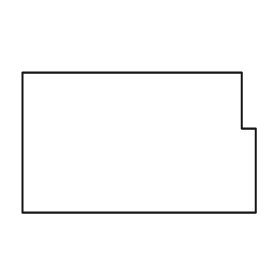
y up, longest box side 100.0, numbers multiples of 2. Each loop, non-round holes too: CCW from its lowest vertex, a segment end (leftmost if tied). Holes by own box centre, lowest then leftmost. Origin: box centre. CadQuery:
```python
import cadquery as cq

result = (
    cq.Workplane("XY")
    .moveTo(-50.0, -30.0)
    .lineTo(50.0, -30.0)
    .lineTo(50.0, 6.0)
    .lineTo(44.0, 6.0)
    .lineTo(44.0, 30.0)
    .lineTo(-50.0, 30.0)
    .close()
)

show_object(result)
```